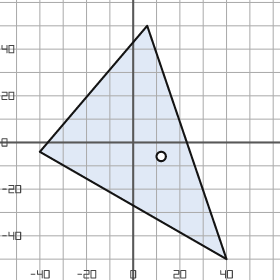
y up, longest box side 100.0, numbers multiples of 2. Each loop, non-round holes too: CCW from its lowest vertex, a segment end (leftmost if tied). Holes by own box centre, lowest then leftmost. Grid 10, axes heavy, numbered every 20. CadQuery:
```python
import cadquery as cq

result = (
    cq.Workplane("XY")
    .moveTo(40.0, -50.0)
    .lineTo(6.0, 50.0)
    .lineTo(-40.0, -4.0)
    .close()
    .moveTo(12.0, -6.0)
    .circle(2.0)
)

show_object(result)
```